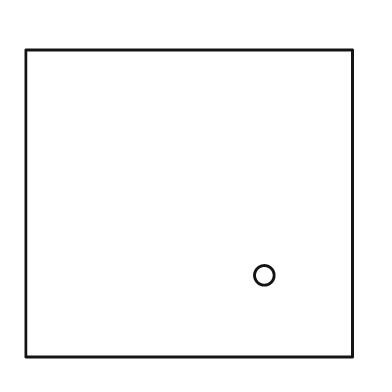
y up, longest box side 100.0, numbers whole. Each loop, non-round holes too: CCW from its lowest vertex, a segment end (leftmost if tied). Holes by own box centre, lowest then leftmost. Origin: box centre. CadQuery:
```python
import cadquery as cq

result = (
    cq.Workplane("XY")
    .moveTo(-50.0, -47.0)
    .lineTo(50.0, -47.0)
    .lineTo(50.0, 47.0)
    .lineTo(-50.0, 47.0)
    .close()
    .moveTo(23.0, -22.0)
    .circle(3.0)
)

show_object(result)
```